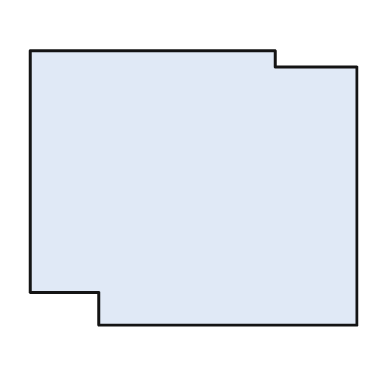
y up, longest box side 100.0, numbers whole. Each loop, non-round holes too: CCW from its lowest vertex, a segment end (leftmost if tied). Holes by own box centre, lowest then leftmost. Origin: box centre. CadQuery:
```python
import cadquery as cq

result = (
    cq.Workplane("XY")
    .moveTo(-29.0, -42.0)
    .lineTo(50.0, -42.0)
    .lineTo(50.0, 37.0)
    .lineTo(25.0, 37.0)
    .lineTo(25.0, 42.0)
    .lineTo(-50.0, 42.0)
    .lineTo(-50.0, -32.0)
    .lineTo(-29.0, -32.0)
    .close()
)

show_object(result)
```